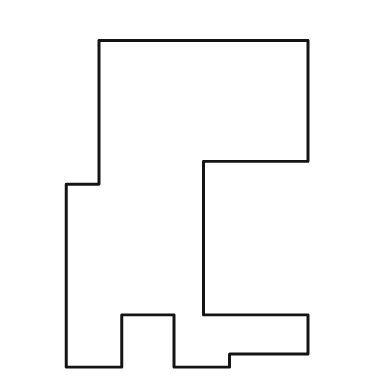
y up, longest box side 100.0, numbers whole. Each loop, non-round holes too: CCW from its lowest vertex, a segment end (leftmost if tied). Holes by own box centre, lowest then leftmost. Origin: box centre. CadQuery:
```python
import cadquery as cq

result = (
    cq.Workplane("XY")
    .moveTo(-37.0, -50.0)
    .lineTo(-20.0, -50.0)
    .lineTo(-20.0, -34.0)
    .lineTo(-4.0, -34.0)
    .lineTo(-4.0, -50.0)
    .lineTo(13.0, -50.0)
    .lineTo(13.0, -46.0)
    .lineTo(37.0, -46.0)
    .lineTo(37.0, -34.0)
    .lineTo(5.0, -34.0)
    .lineTo(5.0, 13.0)
    .lineTo(37.0, 13.0)
    .lineTo(37.0, 50.0)
    .lineTo(-27.0, 50.0)
    .lineTo(-27.0, 6.0)
    .lineTo(-37.0, 6.0)
    .close()
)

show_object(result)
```